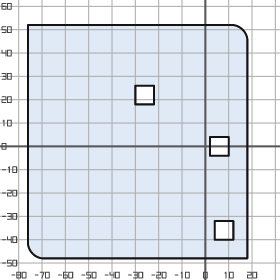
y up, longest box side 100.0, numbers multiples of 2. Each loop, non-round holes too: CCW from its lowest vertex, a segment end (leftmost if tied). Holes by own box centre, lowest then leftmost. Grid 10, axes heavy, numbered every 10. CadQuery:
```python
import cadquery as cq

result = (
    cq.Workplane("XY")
    .moveTo(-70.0, -48.0)
    .lineTo(18.0, -48.0)
    .lineTo(18.0, 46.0)
    .threePointArc((16.0, 50.0), (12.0, 52.0))
    .lineTo(-76.0, 52.0)
    .lineTo(-76.0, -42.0)
    .threePointArc((-74.0, -46.0), (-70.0, -48.0))
    .close()
    .moveTo(4.0, -40.0)
    .lineTo(12.0, -40.0)
    .lineTo(12.0, -32.0)
    .lineTo(4.0, -32.0)
    .close()
    .moveTo(2.0, -4.0)
    .lineTo(10.0, -4.0)
    .lineTo(10.0, 4.0)
    .lineTo(2.0, 4.0)
    .close()
    .moveTo(-30.0, 18.0)
    .lineTo(-22.0, 18.0)
    .lineTo(-22.0, 26.0)
    .lineTo(-30.0, 26.0)
    .close()
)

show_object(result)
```